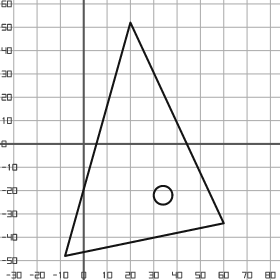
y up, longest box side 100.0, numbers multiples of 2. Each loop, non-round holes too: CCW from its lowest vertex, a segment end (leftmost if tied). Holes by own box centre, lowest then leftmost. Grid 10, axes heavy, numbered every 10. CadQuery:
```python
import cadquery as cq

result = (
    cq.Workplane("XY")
    .moveTo(-8.0, -48.0)
    .lineTo(60.0, -34.0)
    .lineTo(20.0, 52.0)
    .close()
    .moveTo(34.0, -22.0)
    .circle(4.0)
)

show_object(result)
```